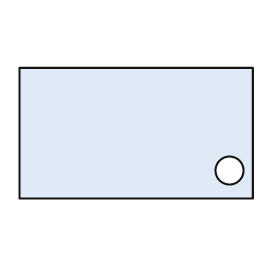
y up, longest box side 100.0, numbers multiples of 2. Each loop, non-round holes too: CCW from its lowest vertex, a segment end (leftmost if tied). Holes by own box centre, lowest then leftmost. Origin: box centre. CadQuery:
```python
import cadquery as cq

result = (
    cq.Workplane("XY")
    .moveTo(-50.0, -28.0)
    .lineTo(50.0, -28.0)
    .lineTo(50.0, 28.0)
    .lineTo(-50.0, 28.0)
    .close()
    .moveTo(40.0, -16.0)
    .circle(6.0)
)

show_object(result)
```